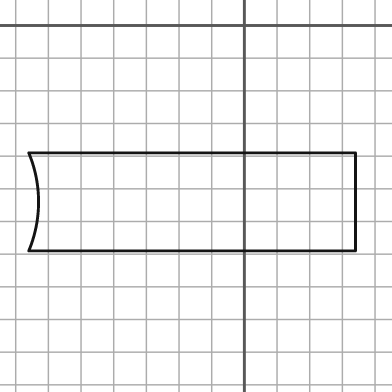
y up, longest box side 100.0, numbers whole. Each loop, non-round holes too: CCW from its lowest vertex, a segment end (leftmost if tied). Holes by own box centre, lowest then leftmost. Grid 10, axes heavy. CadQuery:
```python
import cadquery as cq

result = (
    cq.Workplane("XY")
    .moveTo(-66.0, -69.0)
    .lineTo(34.0, -69.0)
    .lineTo(34.0, -39.0)
    .lineTo(-66.0, -39.0)
    .threePointArc((-63.0, -54.0), (-66.0, -69.0))
    .close()
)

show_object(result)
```